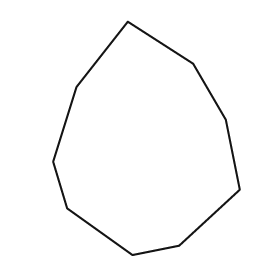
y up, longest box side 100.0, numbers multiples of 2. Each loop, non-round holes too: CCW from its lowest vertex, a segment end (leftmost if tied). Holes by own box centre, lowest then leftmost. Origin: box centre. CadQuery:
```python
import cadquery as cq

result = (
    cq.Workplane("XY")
    .moveTo(-6.0, -50.0)
    .lineTo(14.0, -46.0)
    .lineTo(40.0, -22.0)
    .lineTo(34.0, 8.0)
    .lineTo(20.0, 32.0)
    .lineTo(-8.0, 50.0)
    .lineTo(-30.0, 22.0)
    .lineTo(-40.0, -10.0)
    .lineTo(-34.0, -30.0)
    .close()
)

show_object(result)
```